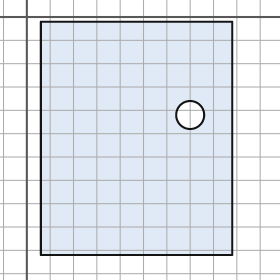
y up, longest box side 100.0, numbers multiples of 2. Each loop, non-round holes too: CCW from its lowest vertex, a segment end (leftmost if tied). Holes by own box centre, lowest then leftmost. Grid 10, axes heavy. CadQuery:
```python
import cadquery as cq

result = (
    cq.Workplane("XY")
    .moveTo(6.0, -102.0)
    .lineTo(88.0, -102.0)
    .lineTo(88.0, -2.0)
    .lineTo(6.0, -2.0)
    .close()
    .moveTo(70.0, -42.0)
    .circle(6.0)
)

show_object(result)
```